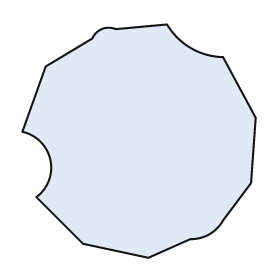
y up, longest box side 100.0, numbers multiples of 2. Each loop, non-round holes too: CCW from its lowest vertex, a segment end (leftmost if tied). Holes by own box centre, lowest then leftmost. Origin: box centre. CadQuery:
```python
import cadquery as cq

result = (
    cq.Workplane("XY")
    .moveTo(4.0, -50.0)
    .lineTo(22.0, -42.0)
    .threePointArc((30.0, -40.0), (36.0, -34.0))
    .lineTo(48.0, -18.0)
    .lineTo(50.0, 10.0)
    .lineTo(36.0, 36.0)
    .threePointArc((22.0, 40.0), (12.0, 50.0))
    .lineTo(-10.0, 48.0)
    .threePointArc((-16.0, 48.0), (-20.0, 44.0))
    .lineTo(-40.0, 32.0)
    .lineTo(-50.0, 4.0)
    .threePointArc((-38.0, -8.0), (-44.0, -24.0))
    .lineTo(-24.0, -44.0)
    .close()
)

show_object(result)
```